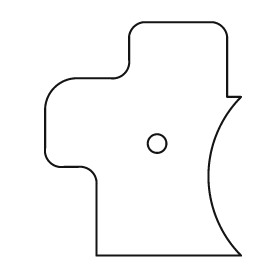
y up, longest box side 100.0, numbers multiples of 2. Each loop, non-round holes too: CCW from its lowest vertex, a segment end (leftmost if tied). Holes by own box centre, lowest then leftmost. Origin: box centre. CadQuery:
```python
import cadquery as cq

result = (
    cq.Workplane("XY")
    .moveTo(-20.0, -50.0)
    .lineTo(42.0, -50.0)
    .threePointArc((28.0, -16.0), (42.0, 18.0))
    .lineTo(36.0, 18.0)
    .lineTo(36.0, 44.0)
    .threePointArc((34.0, 48.0), (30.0, 50.0))
    .lineTo(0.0, 50.0)
    .threePointArc((-4.0, 48.0), (-6.0, 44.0))
    .lineTo(-6.0, 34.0)
    .threePointArc((-8.0, 28.0), (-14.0, 26.0))
    .lineTo(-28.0, 26.0)
    .threePointArc((-38.0, 22.0), (-42.0, 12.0))
    .lineTo(-42.0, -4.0)
    .threePointArc((-40.0, -10.0), (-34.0, -12.0))
    .lineTo(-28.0, -12.0)
    .threePointArc((-22.0, -14.0), (-20.0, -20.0))
    .close()
    .moveTo(6.0, -2.0)
    .circle(4.0)
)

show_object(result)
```